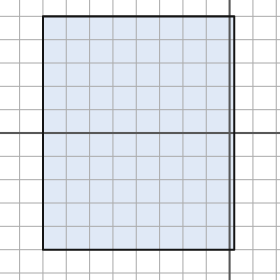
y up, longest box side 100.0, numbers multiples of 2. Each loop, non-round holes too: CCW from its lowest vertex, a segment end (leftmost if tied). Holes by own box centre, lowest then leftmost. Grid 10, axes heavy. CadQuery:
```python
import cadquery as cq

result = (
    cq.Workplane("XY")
    .moveTo(-80.0, -50.0)
    .lineTo(2.0, -50.0)
    .lineTo(2.0, 50.0)
    .lineTo(-80.0, 50.0)
    .close()
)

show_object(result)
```